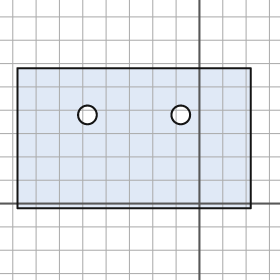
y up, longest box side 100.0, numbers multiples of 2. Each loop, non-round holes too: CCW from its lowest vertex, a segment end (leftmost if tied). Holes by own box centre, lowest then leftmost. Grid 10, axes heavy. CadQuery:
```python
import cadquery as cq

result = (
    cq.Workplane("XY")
    .moveTo(-78.0, -2.0)
    .lineTo(22.0, -2.0)
    .lineTo(22.0, 58.0)
    .lineTo(-78.0, 58.0)
    .close()
    .moveTo(-48.0, 38.0)
    .circle(4.0)
    .moveTo(-8.0, 38.0)
    .circle(4.0)
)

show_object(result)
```